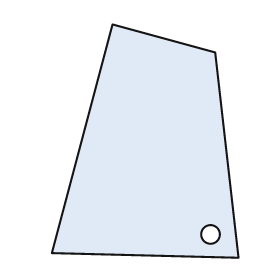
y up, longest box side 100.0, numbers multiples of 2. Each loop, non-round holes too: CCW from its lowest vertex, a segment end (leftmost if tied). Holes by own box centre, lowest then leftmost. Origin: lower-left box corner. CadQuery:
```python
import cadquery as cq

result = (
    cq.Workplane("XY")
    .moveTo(80.0, 0.0)
    .lineTo(70.0, 88.0)
    .lineTo(26.0, 100.0)
    .lineTo(0.0, 2.0)
    .close()
    .moveTo(68.0, 10.0)
    .circle(4.0)
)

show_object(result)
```